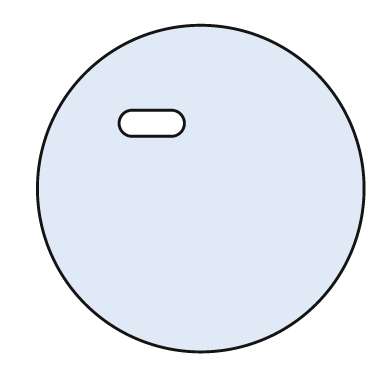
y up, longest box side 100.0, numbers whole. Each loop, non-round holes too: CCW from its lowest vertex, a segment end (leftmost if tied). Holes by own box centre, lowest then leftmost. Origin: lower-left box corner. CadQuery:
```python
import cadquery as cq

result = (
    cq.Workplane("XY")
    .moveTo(50.0, 50.0)
    .circle(50.0)
    .moveTo(29.0, 66.0)
    .lineTo(41.0, 66.0)
    .threePointArc((45.0, 70.0), (41.0, 74.0))
    .lineTo(29.0, 74.0)
    .threePointArc((25.0, 70.0), (29.0, 66.0))
    .close()
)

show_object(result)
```